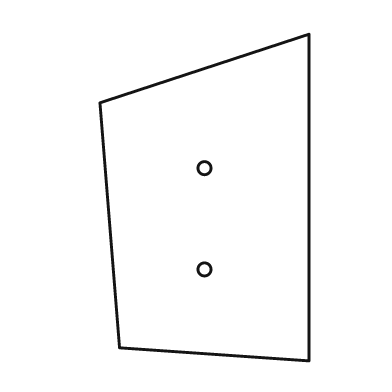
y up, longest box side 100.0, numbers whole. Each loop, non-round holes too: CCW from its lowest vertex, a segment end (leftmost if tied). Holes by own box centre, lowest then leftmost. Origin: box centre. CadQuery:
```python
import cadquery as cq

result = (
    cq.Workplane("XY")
    .moveTo(32.0, -50.0)
    .lineTo(32.0, 50.0)
    .lineTo(-32.0, 29.0)
    .lineTo(-26.0, -46.0)
    .close()
    .moveTo(0.0, -22.0)
    .circle(2.0)
    .moveTo(0.0, 9.0)
    .circle(2.0)
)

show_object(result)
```